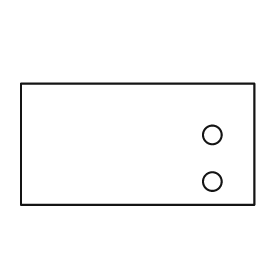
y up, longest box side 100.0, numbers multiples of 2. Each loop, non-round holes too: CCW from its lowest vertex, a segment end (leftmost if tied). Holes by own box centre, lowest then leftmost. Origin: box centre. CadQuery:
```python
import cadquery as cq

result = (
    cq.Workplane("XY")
    .moveTo(-50.0, -26.0)
    .lineTo(50.0, -26.0)
    .lineTo(50.0, 26.0)
    .lineTo(-50.0, 26.0)
    .close()
    .moveTo(32.0, -16.0)
    .circle(4.0)
    .moveTo(32.0, 4.0)
    .circle(4.0)
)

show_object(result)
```